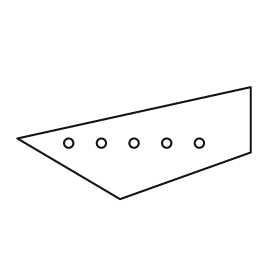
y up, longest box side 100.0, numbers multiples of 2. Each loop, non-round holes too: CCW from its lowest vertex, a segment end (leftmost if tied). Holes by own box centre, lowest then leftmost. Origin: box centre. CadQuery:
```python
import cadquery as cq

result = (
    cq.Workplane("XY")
    .moveTo(-6.0, -24.0)
    .lineTo(50.0, -4.0)
    .lineTo(50.0, 24.0)
    .lineTo(-50.0, 2.0)
    .close()
    .moveTo(-28.0, 0.0)
    .circle(2.0)
    .moveTo(-14.0, 0.0)
    .circle(2.0)
    .moveTo(0.0, 0.0)
    .circle(2.0)
    .moveTo(14.0, 0.0)
    .circle(2.0)
    .moveTo(28.0, 0.0)
    .circle(2.0)
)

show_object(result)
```